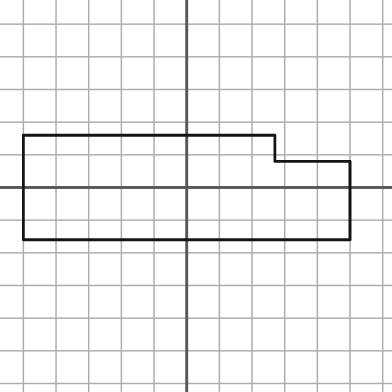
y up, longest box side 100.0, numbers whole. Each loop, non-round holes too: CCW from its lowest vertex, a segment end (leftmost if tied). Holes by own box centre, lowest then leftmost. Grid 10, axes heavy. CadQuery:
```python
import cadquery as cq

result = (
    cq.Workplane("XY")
    .moveTo(-50.0, -16.0)
    .lineTo(50.0, -16.0)
    .lineTo(50.0, 8.0)
    .lineTo(27.0, 8.0)
    .lineTo(27.0, 16.0)
    .lineTo(-50.0, 16.0)
    .close()
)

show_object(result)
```